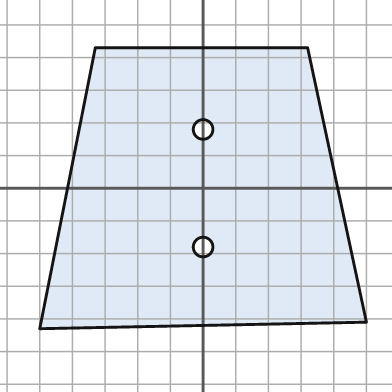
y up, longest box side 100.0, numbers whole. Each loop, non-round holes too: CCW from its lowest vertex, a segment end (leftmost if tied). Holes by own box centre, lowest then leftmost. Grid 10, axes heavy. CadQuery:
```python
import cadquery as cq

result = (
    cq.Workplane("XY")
    .moveTo(-50.0, -43.0)
    .lineTo(50.0, -41.0)
    .lineTo(32.0, 43.0)
    .lineTo(-33.0, 43.0)
    .close()
    .moveTo(0.0, -18.0)
    .circle(3.0)
    .moveTo(0.0, 18.0)
    .circle(3.0)
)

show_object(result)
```